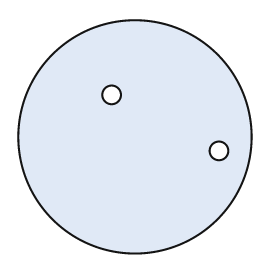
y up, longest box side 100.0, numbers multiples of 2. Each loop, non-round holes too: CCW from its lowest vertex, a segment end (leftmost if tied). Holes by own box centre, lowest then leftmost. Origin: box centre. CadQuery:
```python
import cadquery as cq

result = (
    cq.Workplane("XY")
    .moveTo(0.0, 0.0)
    .circle(50.0)
    .moveTo(36.0, -6.0)
    .circle(4.0)
    .moveTo(-10.0, 18.0)
    .circle(4.0)
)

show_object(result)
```